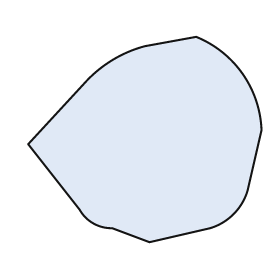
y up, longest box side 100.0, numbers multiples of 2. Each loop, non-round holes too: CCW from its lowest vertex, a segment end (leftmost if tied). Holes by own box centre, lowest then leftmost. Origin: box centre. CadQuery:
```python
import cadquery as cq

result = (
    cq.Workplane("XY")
    .moveTo(2.0, -44.0)
    .lineTo(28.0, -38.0)
    .threePointArc((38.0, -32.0), (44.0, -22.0))
    .lineTo(50.0, 4.0)
    .threePointArc((42.0, 28.0), (22.0, 44.0))
    .lineTo(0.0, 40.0)
    .threePointArc((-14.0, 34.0), (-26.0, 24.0))
    .lineTo(-50.0, -2.0)
    .lineTo(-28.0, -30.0)
    .threePointArc((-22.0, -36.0), (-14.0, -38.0))
    .close()
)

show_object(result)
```